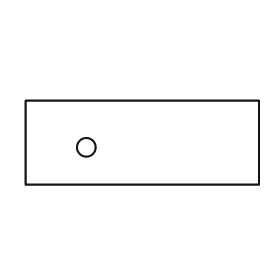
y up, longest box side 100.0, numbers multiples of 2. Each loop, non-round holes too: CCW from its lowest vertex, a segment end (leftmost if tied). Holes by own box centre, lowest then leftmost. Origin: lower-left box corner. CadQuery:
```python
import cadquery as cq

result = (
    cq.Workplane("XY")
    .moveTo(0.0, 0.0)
    .lineTo(100.0, 0.0)
    .lineTo(100.0, 36.0)
    .lineTo(0.0, 36.0)
    .close()
    .moveTo(26.0, 16.0)
    .circle(4.0)
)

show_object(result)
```